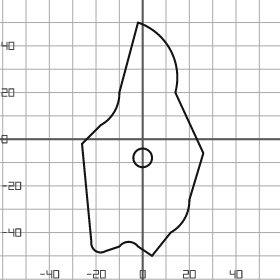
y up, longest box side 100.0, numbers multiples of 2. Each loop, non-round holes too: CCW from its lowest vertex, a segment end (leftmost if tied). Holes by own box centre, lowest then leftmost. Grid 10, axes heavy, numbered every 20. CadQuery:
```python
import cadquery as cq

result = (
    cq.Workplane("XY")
    .moveTo(4.0, -50.0)
    .lineTo(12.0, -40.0)
    .threePointArc((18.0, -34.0), (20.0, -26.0))
    .lineTo(26.0, -6.0)
    .lineTo(14.0, 20.0)
    .threePointArc((12.0, 38.0), (-2.0, 50.0))
    .lineTo(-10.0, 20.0)
    .threePointArc((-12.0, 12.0), (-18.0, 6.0))
    .lineTo(-26.0, -2.0)
    .lineTo(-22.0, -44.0)
    .threePointArc((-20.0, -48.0), (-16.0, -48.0))
    .lineTo(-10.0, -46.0)
    .threePointArc((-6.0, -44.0), (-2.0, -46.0))
    .close()
    .moveTo(0.0, -8.0)
    .circle(4.0)
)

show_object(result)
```